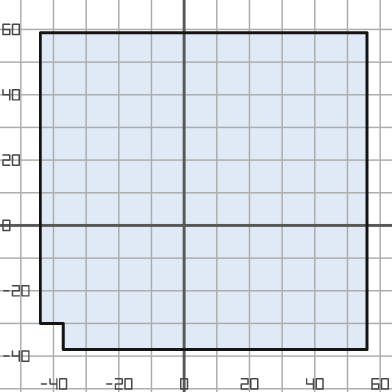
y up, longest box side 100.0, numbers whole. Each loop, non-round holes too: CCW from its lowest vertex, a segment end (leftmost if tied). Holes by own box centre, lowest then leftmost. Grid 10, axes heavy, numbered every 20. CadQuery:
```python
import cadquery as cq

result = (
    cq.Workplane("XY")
    .moveTo(-37.0, -38.0)
    .lineTo(56.0, -38.0)
    .lineTo(56.0, 59.0)
    .lineTo(-44.0, 59.0)
    .lineTo(-44.0, -30.0)
    .lineTo(-37.0, -30.0)
    .close()
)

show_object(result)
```